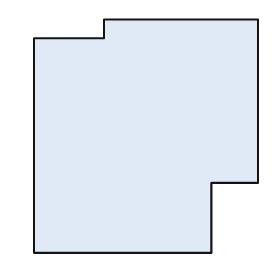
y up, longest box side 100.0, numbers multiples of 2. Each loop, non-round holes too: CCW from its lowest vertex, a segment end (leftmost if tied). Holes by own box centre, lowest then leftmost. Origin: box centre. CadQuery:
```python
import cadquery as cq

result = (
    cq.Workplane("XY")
    .moveTo(-48.0, -50.0)
    .lineTo(28.0, -50.0)
    .lineTo(28.0, -20.0)
    .lineTo(48.0, -20.0)
    .lineTo(48.0, 50.0)
    .lineTo(-18.0, 50.0)
    .lineTo(-18.0, 42.0)
    .lineTo(-48.0, 42.0)
    .close()
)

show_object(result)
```